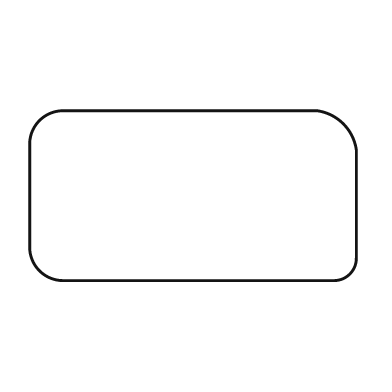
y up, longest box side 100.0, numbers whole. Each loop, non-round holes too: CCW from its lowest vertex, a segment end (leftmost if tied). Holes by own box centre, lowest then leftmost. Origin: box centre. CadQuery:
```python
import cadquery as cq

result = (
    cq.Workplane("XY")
    .moveTo(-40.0, -26.0)
    .lineTo(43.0, -26.0)
    .threePointArc((48.0, -24.0), (50.0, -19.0))
    .lineTo(50.0, 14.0)
    .threePointArc((46.0, 22.0), (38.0, 26.0))
    .lineTo(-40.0, 26.0)
    .threePointArc((-47.0, 23.0), (-50.0, 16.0))
    .lineTo(-50.0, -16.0)
    .threePointArc((-47.0, -23.0), (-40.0, -26.0))
    .close()
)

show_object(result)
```